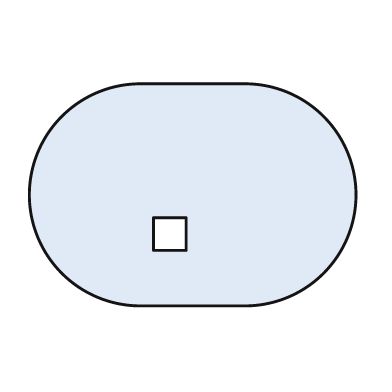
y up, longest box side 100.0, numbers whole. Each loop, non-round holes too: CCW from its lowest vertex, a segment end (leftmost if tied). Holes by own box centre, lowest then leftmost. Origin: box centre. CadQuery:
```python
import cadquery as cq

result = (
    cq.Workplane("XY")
    .moveTo(-16.0, -34.0)
    .lineTo(16.0, -34.0)
    .threePointArc((50.0, 0.0), (16.0, 34.0))
    .lineTo(-16.0, 34.0)
    .threePointArc((-50.0, 0.0), (-16.0, -34.0))
    .close()
    .moveTo(-12.0, -17.0)
    .lineTo(-2.0, -17.0)
    .lineTo(-2.0, -7.0)
    .lineTo(-12.0, -7.0)
    .close()
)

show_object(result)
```